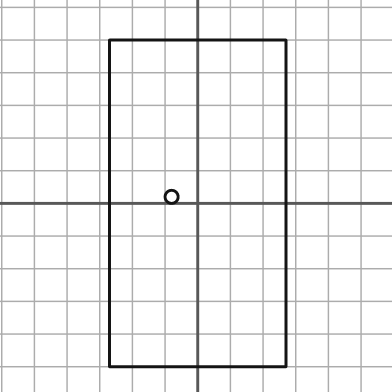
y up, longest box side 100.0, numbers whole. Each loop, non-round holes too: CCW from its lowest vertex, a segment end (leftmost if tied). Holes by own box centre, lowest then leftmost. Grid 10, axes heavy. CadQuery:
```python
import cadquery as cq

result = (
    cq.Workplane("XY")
    .moveTo(-27.0, -50.0)
    .lineTo(27.0, -50.0)
    .lineTo(27.0, 50.0)
    .lineTo(-27.0, 50.0)
    .close()
    .moveTo(-8.0, 2.0)
    .circle(2.0)
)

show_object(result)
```